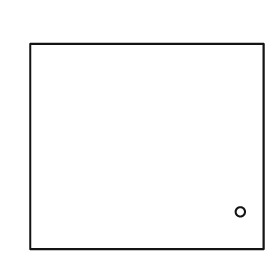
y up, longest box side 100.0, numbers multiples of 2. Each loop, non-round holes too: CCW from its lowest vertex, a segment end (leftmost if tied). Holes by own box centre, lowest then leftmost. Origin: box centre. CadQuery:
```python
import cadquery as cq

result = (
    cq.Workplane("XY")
    .moveTo(-50.0, -44.0)
    .lineTo(50.0, -44.0)
    .lineTo(50.0, 44.0)
    .lineTo(-50.0, 44.0)
    .close()
    .moveTo(40.0, -28.0)
    .circle(2.0)
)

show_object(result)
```